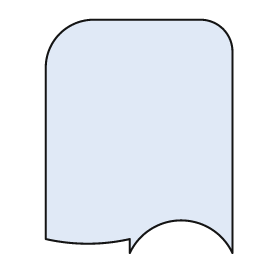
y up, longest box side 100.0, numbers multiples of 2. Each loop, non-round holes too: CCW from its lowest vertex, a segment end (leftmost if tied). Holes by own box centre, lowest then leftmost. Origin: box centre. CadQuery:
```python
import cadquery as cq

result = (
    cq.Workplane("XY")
    .moveTo(-4.0, -50.0)
    .threePointArc((18.0, -36.0), (40.0, -50.0))
    .lineTo(40.0, 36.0)
    .threePointArc((36.0, 46.0), (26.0, 50.0))
    .lineTo(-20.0, 50.0)
    .threePointArc((-34.0, 44.0), (-40.0, 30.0))
    .lineTo(-40.0, -44.0)
    .threePointArc((-22.0, -46.0), (-4.0, -44.0))
    .close()
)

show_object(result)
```